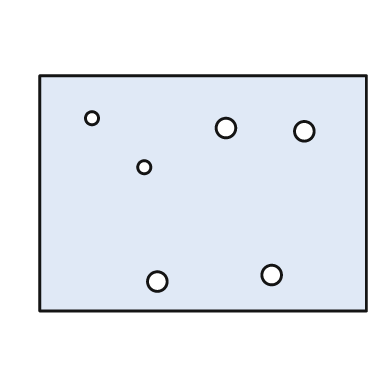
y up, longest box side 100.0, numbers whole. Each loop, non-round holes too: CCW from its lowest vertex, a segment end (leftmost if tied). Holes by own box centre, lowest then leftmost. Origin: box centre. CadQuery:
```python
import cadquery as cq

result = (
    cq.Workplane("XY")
    .moveTo(-50.0, -36.0)
    .lineTo(50.0, -36.0)
    .lineTo(50.0, 36.0)
    .lineTo(-50.0, 36.0)
    .close()
    .moveTo(-14.0, -27.0)
    .circle(3.0)
    .moveTo(21.0, -25.0)
    .circle(3.0)
    .moveTo(-18.0, 8.0)
    .circle(2.0)
    .moveTo(31.0, 19.0)
    .circle(3.0)
    .moveTo(7.0, 20.0)
    .circle(3.0)
    .moveTo(-34.0, 23.0)
    .circle(2.0)
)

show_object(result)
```